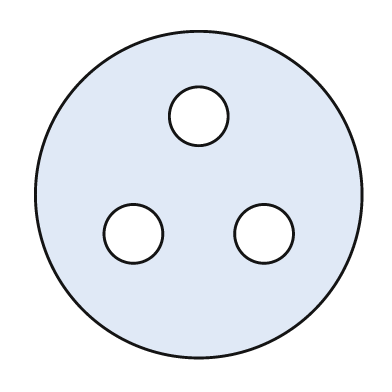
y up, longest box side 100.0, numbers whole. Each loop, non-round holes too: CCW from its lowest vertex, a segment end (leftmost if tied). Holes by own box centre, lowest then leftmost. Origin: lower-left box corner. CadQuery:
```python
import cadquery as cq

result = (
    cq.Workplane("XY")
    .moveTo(50.0, 50.0)
    .circle(50.0)
    .moveTo(30.0, 38.0)
    .circle(9.0)
    .moveTo(70.0, 38.0)
    .circle(9.0)
    .moveTo(50.0, 74.0)
    .circle(9.0)
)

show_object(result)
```